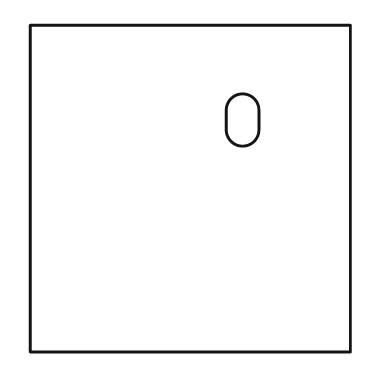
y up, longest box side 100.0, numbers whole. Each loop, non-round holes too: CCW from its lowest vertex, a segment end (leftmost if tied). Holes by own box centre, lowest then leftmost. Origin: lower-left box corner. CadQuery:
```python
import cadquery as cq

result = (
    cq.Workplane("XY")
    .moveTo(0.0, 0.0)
    .lineTo(98.0, 0.0)
    .lineTo(98.0, 100.0)
    .lineTo(0.0, 100.0)
    .close()
    .moveTo(60.0, 68.0)
    .threePointArc((65.0, 63.0), (70.0, 68.0))
    .lineTo(70.0, 74.0)
    .threePointArc((65.0, 79.0), (60.0, 74.0))
    .close()
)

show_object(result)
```